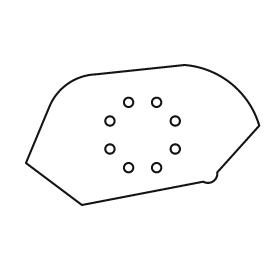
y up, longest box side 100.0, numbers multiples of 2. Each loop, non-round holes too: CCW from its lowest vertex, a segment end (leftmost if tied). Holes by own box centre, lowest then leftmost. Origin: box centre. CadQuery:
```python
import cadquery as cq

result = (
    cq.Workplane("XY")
    .moveTo(-26.0, -30.0)
    .lineTo(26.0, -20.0)
    .threePointArc((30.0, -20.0), (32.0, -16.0))
    .lineTo(50.0, 4.0)
    .threePointArc((38.0, 22.0), (18.0, 30.0))
    .lineTo(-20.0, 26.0)
    .threePointArc((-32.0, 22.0), (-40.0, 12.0))
    .lineTo(-50.0, -12.0)
    .close()
    .moveTo(-6.0, -14.0)
    .circle(2.0)
    .moveTo(6.0, -14.0)
    .circle(2.0)
    .moveTo(-14.0, -6.0)
    .circle(2.0)
    .moveTo(14.0, -6.0)
    .circle(2.0)
    .moveTo(-14.0, 6.0)
    .circle(2.0)
    .moveTo(14.0, 6.0)
    .circle(2.0)
    .moveTo(-6.0, 14.0)
    .circle(2.0)
    .moveTo(6.0, 14.0)
    .circle(2.0)
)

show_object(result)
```